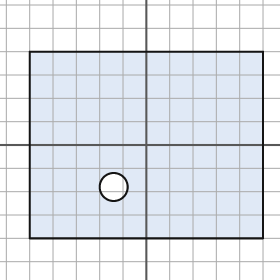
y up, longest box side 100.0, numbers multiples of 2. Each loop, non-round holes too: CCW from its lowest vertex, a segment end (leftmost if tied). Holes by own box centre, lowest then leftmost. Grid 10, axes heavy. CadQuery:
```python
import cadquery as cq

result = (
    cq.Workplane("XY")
    .moveTo(-50.0, -40.0)
    .lineTo(50.0, -40.0)
    .lineTo(50.0, 40.0)
    .lineTo(-50.0, 40.0)
    .close()
    .moveTo(-14.0, -18.0)
    .circle(6.0)
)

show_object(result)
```